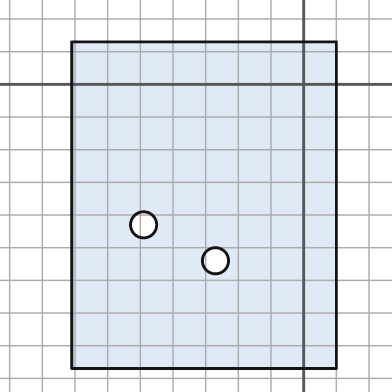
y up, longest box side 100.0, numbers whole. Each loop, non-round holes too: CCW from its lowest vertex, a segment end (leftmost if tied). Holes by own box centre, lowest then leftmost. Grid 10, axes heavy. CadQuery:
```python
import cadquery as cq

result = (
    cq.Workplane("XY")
    .moveTo(-71.0, -87.0)
    .lineTo(10.0, -87.0)
    .lineTo(10.0, 13.0)
    .lineTo(-71.0, 13.0)
    .close()
    .moveTo(-27.0, -54.0)
    .circle(4.0)
    .moveTo(-49.0, -43.0)
    .circle(4.0)
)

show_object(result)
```